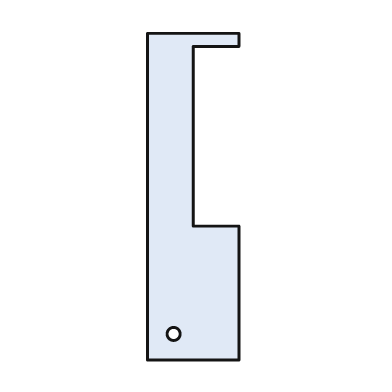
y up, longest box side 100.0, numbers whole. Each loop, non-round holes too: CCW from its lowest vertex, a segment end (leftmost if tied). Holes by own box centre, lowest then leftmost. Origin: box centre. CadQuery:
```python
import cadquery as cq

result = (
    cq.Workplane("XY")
    .moveTo(-14.0, -50.0)
    .lineTo(14.0, -50.0)
    .lineTo(14.0, -9.0)
    .lineTo(0.0, -9.0)
    .lineTo(0.0, 46.0)
    .lineTo(14.0, 46.0)
    .lineTo(14.0, 50.0)
    .lineTo(-14.0, 50.0)
    .close()
    .moveTo(-6.0, -42.0)
    .circle(2.0)
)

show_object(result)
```